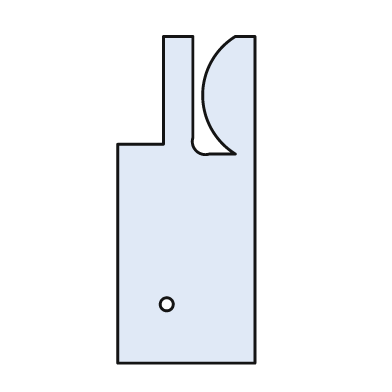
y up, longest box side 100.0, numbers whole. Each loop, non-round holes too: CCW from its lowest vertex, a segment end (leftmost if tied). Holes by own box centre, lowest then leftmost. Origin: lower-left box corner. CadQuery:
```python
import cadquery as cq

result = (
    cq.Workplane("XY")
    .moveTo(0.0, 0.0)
    .lineTo(42.0, 0.0)
    .lineTo(42.0, 100.0)
    .lineTo(36.0, 100.0)
    .threePointArc((26.0, 82.0), (36.0, 64.0))
    .lineTo(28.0, 64.0)
    .threePointArc((24.0, 65.0), (23.0, 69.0))
    .lineTo(23.0, 100.0)
    .lineTo(14.0, 100.0)
    .lineTo(14.0, 67.0)
    .lineTo(0.0, 67.0)
    .close()
    .moveTo(15.0, 18.0)
    .circle(2.0)
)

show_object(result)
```